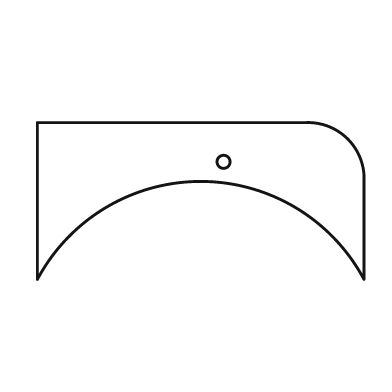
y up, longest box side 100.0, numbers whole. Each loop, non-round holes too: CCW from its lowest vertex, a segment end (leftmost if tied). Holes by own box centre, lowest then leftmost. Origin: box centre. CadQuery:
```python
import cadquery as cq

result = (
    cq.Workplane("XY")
    .moveTo(-50.0, -24.0)
    .threePointArc((0.0, 6.0), (50.0, -24.0))
    .lineTo(50.0, 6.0)
    .threePointArc((45.0, 19.0), (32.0, 24.0))
    .lineTo(-50.0, 24.0)
    .close()
    .moveTo(7.0, 12.0)
    .circle(2.0)
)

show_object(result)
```